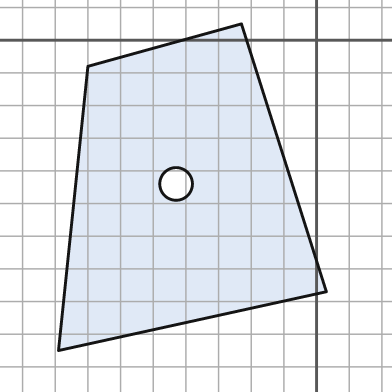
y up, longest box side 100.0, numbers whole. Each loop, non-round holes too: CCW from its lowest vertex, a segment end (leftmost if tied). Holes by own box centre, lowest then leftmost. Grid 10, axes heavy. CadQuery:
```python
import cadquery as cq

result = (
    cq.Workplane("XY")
    .moveTo(-79.0, -95.0)
    .lineTo(3.0, -77.0)
    .lineTo(-23.0, 5.0)
    .lineTo(-70.0, -8.0)
    .close()
    .moveTo(-43.0, -44.0)
    .circle(5.0)
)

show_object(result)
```